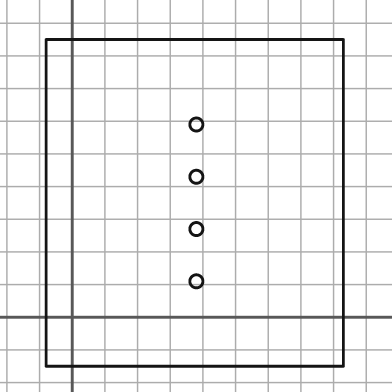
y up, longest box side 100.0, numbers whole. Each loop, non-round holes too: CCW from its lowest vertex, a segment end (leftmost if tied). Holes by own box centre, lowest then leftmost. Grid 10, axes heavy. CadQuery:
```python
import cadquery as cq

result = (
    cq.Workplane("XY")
    .moveTo(-8.0, -15.0)
    .lineTo(83.0, -15.0)
    .lineTo(83.0, 85.0)
    .lineTo(-8.0, 85.0)
    .close()
    .moveTo(38.0, 11.0)
    .circle(2.0)
    .moveTo(38.0, 27.0)
    .circle(2.0)
    .moveTo(38.0, 43.0)
    .circle(2.0)
    .moveTo(38.0, 59.0)
    .circle(2.0)
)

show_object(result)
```